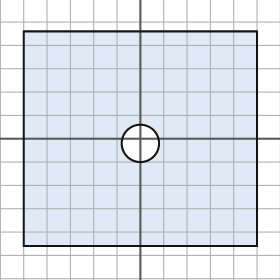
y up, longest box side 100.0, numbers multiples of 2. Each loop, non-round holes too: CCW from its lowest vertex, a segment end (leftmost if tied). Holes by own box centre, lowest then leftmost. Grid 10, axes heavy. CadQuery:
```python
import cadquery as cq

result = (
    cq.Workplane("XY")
    .moveTo(-50.0, -46.0)
    .lineTo(50.0, -46.0)
    .lineTo(50.0, 46.0)
    .lineTo(-50.0, 46.0)
    .close()
    .moveTo(0.0, -2.0)
    .circle(8.0)
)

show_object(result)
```